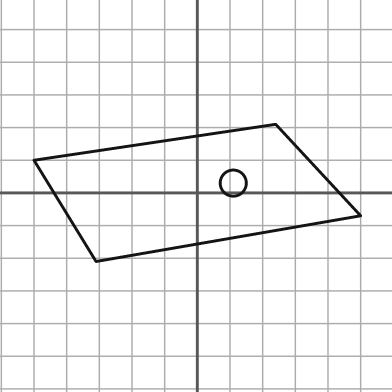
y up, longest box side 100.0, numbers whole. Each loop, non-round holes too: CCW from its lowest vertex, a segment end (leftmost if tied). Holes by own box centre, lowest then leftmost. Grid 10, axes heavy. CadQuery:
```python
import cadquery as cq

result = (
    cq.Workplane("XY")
    .moveTo(-31.0, -21.0)
    .lineTo(50.0, -7.0)
    .lineTo(24.0, 21.0)
    .lineTo(-50.0, 10.0)
    .close()
    .moveTo(11.0, 3.0)
    .circle(4.0)
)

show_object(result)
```